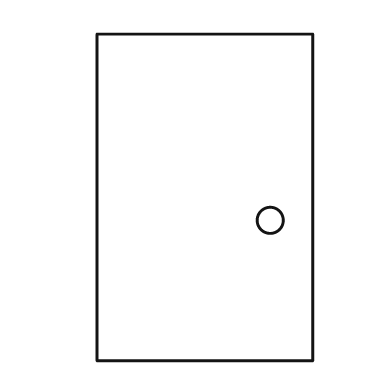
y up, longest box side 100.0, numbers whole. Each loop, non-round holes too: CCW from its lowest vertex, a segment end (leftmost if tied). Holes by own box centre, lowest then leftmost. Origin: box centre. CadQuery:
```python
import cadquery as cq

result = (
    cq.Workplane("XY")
    .moveTo(-33.0, -50.0)
    .lineTo(33.0, -50.0)
    .lineTo(33.0, 50.0)
    .lineTo(-33.0, 50.0)
    .close()
    .moveTo(20.0, -7.0)
    .circle(4.0)
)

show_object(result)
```